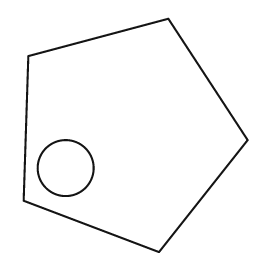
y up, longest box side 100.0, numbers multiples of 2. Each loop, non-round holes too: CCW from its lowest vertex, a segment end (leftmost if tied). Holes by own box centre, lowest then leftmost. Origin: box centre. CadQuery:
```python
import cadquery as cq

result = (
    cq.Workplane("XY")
    .moveTo(10.0, -50.0)
    .lineTo(48.0, -2.0)
    .lineTo(14.0, 50.0)
    .lineTo(-46.0, 34.0)
    .lineTo(-48.0, -28.0)
    .close()
    .moveTo(-30.0, -14.0)
    .circle(12.0)
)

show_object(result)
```